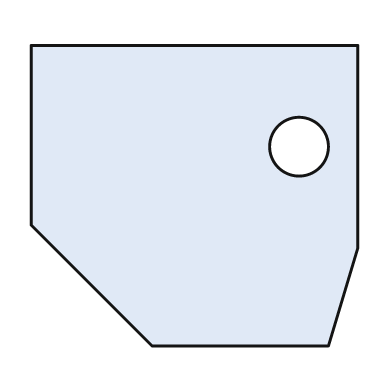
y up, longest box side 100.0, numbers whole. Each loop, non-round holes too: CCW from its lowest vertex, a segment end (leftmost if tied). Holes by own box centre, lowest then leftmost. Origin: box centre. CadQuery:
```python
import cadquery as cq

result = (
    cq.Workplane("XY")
    .moveTo(-13.0, -46.0)
    .lineTo(41.0, -46.0)
    .lineTo(50.0, -16.0)
    .lineTo(50.0, 46.0)
    .lineTo(-50.0, 46.0)
    .lineTo(-50.0, -9.0)
    .close()
    .moveTo(32.0, 15.0)
    .circle(9.0)
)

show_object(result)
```